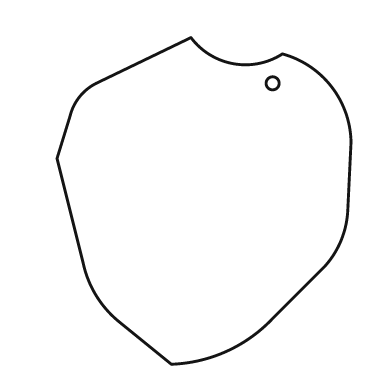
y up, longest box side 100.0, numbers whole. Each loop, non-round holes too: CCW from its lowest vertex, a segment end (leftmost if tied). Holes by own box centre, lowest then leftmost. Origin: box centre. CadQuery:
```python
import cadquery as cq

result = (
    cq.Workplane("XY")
    .moveTo(-10.0, -50.0)
    .threePointArc((7.0, -46.0), (21.0, -36.0))
    .lineTo(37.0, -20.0)
    .threePointArc((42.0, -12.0), (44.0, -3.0))
    .lineTo(45.0, 18.0)
    .threePointArc((39.0, 35.0), (24.0, 45.0))
    .threePointArc((9.0, 42.0), (-4.0, 50.0))
    .lineTo(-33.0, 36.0)
    .threePointArc((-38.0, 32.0), (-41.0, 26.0))
    .lineTo(-45.0, 13.0)
    .lineTo(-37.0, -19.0)
    .threePointArc((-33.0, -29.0), (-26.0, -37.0))
    .close()
    .moveTo(21.0, 36.0)
    .circle(2.0)
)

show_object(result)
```